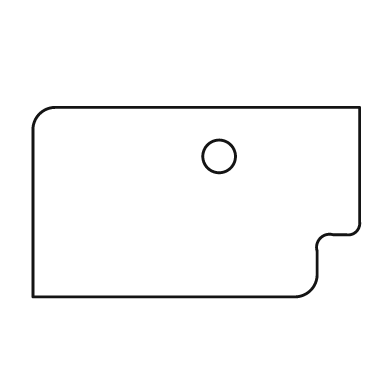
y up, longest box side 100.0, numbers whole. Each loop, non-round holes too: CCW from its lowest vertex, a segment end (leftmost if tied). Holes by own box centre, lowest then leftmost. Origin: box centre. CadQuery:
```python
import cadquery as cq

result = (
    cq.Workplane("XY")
    .moveTo(-50.0, -29.0)
    .lineTo(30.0, -29.0)
    .threePointArc((35.0, -27.0), (37.0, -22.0))
    .lineTo(37.0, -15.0)
    .threePointArc((38.0, -11.0), (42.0, -10.0))
    .lineTo(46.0, -10.0)
    .threePointArc((49.0, -9.0), (50.0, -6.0))
    .lineTo(50.0, 29.0)
    .lineTo(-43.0, 29.0)
    .threePointArc((-48.0, 27.0), (-50.0, 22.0))
    .close()
    .moveTo(7.0, 14.0)
    .circle(5.0)
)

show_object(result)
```